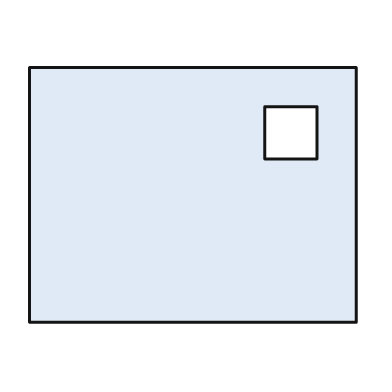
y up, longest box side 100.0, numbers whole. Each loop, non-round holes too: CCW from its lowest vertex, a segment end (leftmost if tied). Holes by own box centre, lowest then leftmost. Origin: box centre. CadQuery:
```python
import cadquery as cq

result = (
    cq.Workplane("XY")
    .moveTo(-50.0, -39.0)
    .lineTo(50.0, -39.0)
    .lineTo(50.0, 39.0)
    .lineTo(-50.0, 39.0)
    .close()
    .moveTo(22.0, 11.0)
    .lineTo(38.0, 11.0)
    .lineTo(38.0, 27.0)
    .lineTo(22.0, 27.0)
    .close()
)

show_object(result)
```